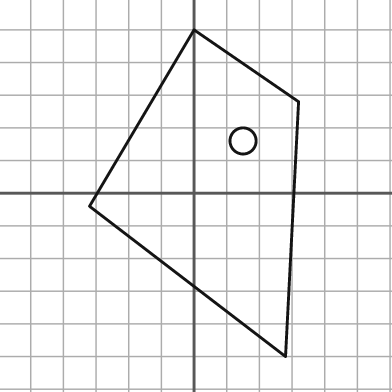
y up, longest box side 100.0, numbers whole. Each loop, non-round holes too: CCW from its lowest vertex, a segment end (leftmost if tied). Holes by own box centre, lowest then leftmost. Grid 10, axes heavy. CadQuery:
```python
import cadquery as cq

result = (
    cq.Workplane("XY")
    .moveTo(28.0, -50.0)
    .lineTo(32.0, 28.0)
    .lineTo(0.0, 50.0)
    .lineTo(-32.0, -4.0)
    .close()
    .moveTo(15.0, 16.0)
    .circle(4.0)
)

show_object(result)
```